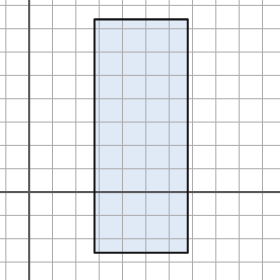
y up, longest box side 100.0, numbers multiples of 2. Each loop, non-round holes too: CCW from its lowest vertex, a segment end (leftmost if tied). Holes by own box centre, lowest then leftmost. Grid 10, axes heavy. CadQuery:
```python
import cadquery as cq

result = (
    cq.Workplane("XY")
    .moveTo(28.0, -26.0)
    .lineTo(68.0, -26.0)
    .lineTo(68.0, 74.0)
    .lineTo(28.0, 74.0)
    .close()
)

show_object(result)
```